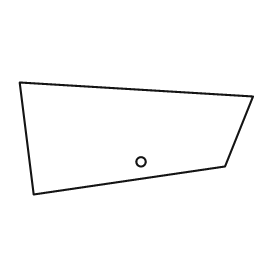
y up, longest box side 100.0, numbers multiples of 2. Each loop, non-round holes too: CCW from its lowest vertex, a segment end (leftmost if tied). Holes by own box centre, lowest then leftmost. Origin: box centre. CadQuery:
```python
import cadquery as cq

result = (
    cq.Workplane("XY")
    .moveTo(-44.0, -24.0)
    .lineTo(38.0, -12.0)
    .lineTo(50.0, 18.0)
    .lineTo(-50.0, 24.0)
    .close()
    .moveTo(2.0, -10.0)
    .circle(2.0)
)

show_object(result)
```